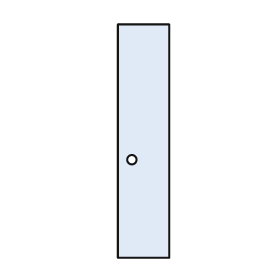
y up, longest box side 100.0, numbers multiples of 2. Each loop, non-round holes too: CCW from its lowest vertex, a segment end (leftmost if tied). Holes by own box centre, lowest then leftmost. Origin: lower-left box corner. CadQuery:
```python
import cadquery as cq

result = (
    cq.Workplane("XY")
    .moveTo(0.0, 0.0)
    .lineTo(22.0, 0.0)
    .lineTo(22.0, 100.0)
    .lineTo(0.0, 100.0)
    .close()
    .moveTo(6.0, 42.0)
    .circle(2.0)
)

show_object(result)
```